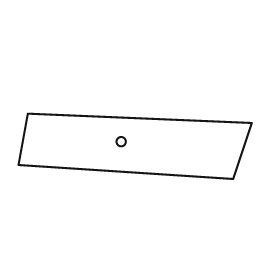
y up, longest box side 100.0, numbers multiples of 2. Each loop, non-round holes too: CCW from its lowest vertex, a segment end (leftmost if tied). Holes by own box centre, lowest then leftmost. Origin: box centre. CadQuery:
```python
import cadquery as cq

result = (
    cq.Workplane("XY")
    .moveTo(42.0, -14.0)
    .lineTo(50.0, 10.0)
    .lineTo(-46.0, 14.0)
    .lineTo(-50.0, -8.0)
    .close()
    .moveTo(-6.0, 2.0)
    .circle(2.0)
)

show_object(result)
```